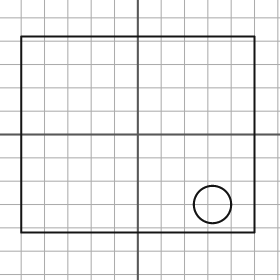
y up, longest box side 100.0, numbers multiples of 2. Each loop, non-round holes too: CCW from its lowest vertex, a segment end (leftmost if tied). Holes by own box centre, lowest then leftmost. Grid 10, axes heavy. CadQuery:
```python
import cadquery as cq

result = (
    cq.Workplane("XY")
    .moveTo(-50.0, -42.0)
    .lineTo(50.0, -42.0)
    .lineTo(50.0, 42.0)
    .lineTo(-50.0, 42.0)
    .close()
    .moveTo(32.0, -30.0)
    .circle(8.0)
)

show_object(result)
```